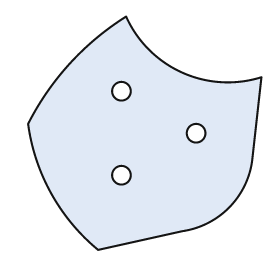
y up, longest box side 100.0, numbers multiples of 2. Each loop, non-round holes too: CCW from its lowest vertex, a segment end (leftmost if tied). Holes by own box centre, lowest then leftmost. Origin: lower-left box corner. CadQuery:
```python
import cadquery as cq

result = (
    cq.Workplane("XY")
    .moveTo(30.0, 0.0)
    .lineTo(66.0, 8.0)
    .threePointArc((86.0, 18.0), (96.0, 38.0))
    .lineTo(100.0, 74.0)
    .threePointArc((66.0, 76.0), (42.0, 100.0))
    .threePointArc((18.0, 80.0), (0.0, 54.0))
    .threePointArc((10.0, 24.0), (30.0, 0.0))
    .close()
    .moveTo(40.0, 32.0)
    .circle(4.0)
    .moveTo(72.0, 50.0)
    .circle(4.0)
    .moveTo(40.0, 68.0)
    .circle(4.0)
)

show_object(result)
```